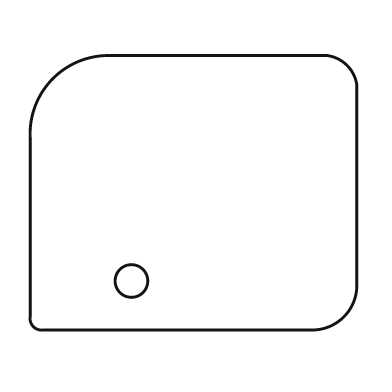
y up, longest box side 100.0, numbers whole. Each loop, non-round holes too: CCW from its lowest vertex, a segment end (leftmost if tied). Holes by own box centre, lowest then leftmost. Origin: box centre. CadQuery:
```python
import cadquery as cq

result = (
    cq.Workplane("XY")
    .moveTo(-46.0, -42.0)
    .lineTo(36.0, -42.0)
    .threePointArc((46.0, -38.0), (50.0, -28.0))
    .lineTo(50.0, 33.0)
    .threePointArc((47.0, 39.0), (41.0, 42.0))
    .lineTo(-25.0, 42.0)
    .threePointArc((-43.0, 35.0), (-50.0, 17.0))
    .lineTo(-50.0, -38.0)
    .threePointArc((-49.0, -41.0), (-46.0, -42.0))
    .close()
    .moveTo(-19.0, -27.0)
    .circle(5.0)
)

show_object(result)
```